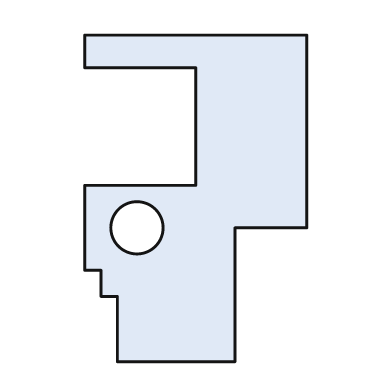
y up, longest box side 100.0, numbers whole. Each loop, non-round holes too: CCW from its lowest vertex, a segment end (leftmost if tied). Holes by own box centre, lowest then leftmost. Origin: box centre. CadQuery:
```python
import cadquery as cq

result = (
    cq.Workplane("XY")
    .moveTo(-24.0, -50.0)
    .lineTo(12.0, -50.0)
    .lineTo(12.0, -9.0)
    .lineTo(34.0, -9.0)
    .lineTo(34.0, 50.0)
    .lineTo(-34.0, 50.0)
    .lineTo(-34.0, 40.0)
    .lineTo(0.0, 40.0)
    .lineTo(0.0, 4.0)
    .lineTo(-34.0, 4.0)
    .lineTo(-34.0, -22.0)
    .lineTo(-29.0, -22.0)
    .lineTo(-29.0, -30.0)
    .lineTo(-24.0, -30.0)
    .close()
    .moveTo(-18.0, -9.0)
    .circle(8.0)
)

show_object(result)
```